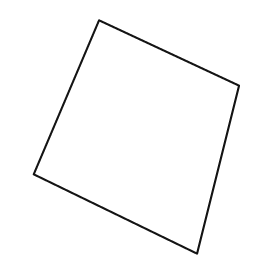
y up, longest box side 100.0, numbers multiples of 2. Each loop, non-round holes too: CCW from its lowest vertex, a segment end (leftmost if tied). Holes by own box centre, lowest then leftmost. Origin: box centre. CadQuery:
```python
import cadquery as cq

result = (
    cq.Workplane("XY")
    .moveTo(26.0, -50.0)
    .lineTo(44.0, 22.0)
    .lineTo(-16.0, 50.0)
    .lineTo(-44.0, -16.0)
    .close()
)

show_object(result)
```